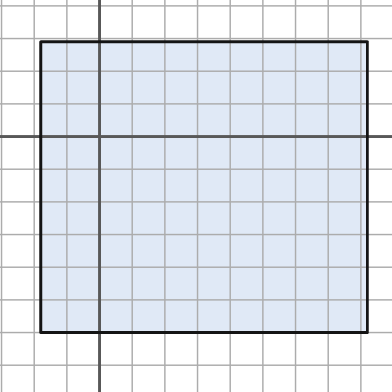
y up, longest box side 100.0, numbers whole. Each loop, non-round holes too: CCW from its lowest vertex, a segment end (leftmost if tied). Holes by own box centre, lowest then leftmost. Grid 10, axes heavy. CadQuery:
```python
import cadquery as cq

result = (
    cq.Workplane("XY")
    .moveTo(-18.0, -60.0)
    .lineTo(82.0, -60.0)
    .lineTo(82.0, 29.0)
    .lineTo(-18.0, 29.0)
    .close()
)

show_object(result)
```